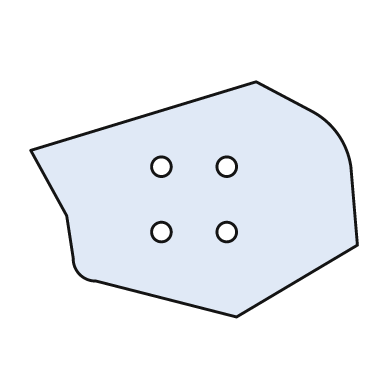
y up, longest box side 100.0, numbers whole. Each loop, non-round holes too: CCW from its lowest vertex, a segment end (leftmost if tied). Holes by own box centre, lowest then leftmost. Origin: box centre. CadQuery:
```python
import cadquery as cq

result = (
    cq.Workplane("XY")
    .moveTo(13.0, -36.0)
    .lineTo(50.0, -14.0)
    .lineTo(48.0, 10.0)
    .threePointArc((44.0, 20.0), (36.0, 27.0))
    .lineTo(19.0, 36.0)
    .lineTo(-50.0, 15.0)
    .lineTo(-39.0, -5.0)
    .lineTo(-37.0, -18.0)
    .threePointArc((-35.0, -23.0), (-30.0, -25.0))
    .close()
    .moveTo(-10.0, -10.0)
    .circle(3.0)
    .moveTo(10.0, -10.0)
    .circle(3.0)
    .moveTo(-10.0, 10.0)
    .circle(3.0)
    .moveTo(10.0, 10.0)
    .circle(3.0)
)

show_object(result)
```